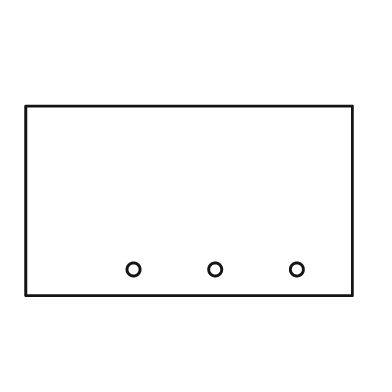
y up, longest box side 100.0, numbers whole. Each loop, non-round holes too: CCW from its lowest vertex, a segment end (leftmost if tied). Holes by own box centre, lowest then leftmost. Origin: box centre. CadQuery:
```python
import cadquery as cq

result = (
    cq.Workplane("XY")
    .moveTo(-50.0, -29.0)
    .lineTo(50.0, -29.0)
    .lineTo(50.0, 29.0)
    .lineTo(-50.0, 29.0)
    .close()
    .moveTo(-17.0, -21.0)
    .circle(2.0)
    .moveTo(8.0, -21.0)
    .circle(2.0)
    .moveTo(33.0, -21.0)
    .circle(2.0)
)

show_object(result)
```